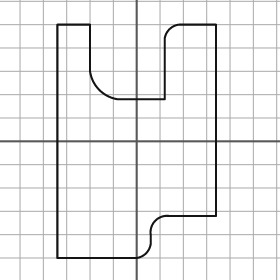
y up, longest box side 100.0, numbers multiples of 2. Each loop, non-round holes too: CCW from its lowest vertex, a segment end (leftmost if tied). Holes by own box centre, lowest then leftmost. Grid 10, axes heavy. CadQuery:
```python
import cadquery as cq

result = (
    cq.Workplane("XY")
    .moveTo(-34.0, -50.0)
    .lineTo(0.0, -50.0)
    .threePointArc((4.0, -48.0), (6.0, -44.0))
    .lineTo(6.0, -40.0)
    .threePointArc((8.0, -34.0), (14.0, -32.0))
    .lineTo(34.0, -32.0)
    .lineTo(34.0, 50.0)
    .lineTo(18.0, 50.0)
    .threePointArc((14.0, 48.0), (12.0, 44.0))
    .lineTo(12.0, 18.0)
    .lineTo(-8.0, 18.0)
    .threePointArc((-16.0, 22.0), (-20.0, 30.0))
    .lineTo(-20.0, 50.0)
    .lineTo(-34.0, 50.0)
    .close()
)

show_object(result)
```